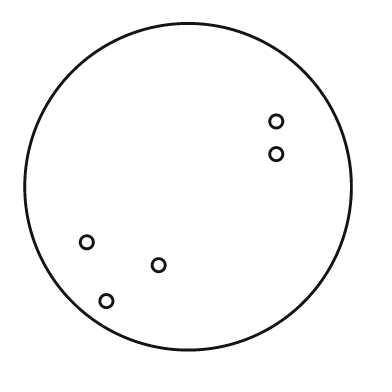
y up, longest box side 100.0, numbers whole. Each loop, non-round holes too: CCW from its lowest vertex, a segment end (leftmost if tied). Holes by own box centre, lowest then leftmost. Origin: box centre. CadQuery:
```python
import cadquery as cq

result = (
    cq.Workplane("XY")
    .moveTo(0.0, 0.0)
    .circle(50.0)
    .moveTo(-25.0, -35.0)
    .circle(2.0)
    .moveTo(-9.0, -24.0)
    .circle(2.0)
    .moveTo(-31.0, -17.0)
    .circle(2.0)
    .moveTo(27.0, 10.0)
    .circle(2.0)
    .moveTo(27.0, 20.0)
    .circle(2.0)
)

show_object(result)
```